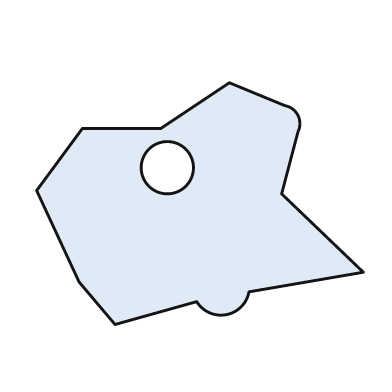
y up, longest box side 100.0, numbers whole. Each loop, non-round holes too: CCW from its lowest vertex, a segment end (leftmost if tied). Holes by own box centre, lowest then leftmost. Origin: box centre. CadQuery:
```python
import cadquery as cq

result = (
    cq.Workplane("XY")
    .moveTo(-26.0, -37.0)
    .lineTo(-1.0, -30.0)
    .threePointArc((8.0, -34.0), (15.0, -27.0))
    .lineTo(50.0, -21.0)
    .lineTo(25.0, 3.0)
    .lineTo(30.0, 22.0)
    .threePointArc((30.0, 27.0), (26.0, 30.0))
    .lineTo(9.0, 37.0)
    .lineTo(-12.0, 23.0)
    .lineTo(-36.0, 23.0)
    .lineTo(-50.0, 4.0)
    .lineTo(-37.0, -24.0)
    .close()
    .moveTo(-10.0, 11.0)
    .circle(8.0)
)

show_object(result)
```